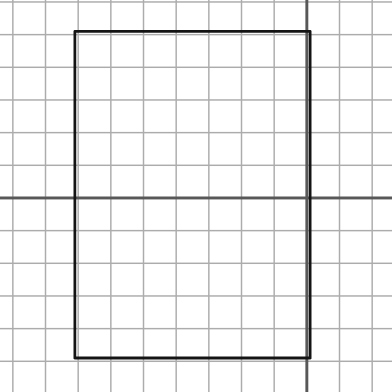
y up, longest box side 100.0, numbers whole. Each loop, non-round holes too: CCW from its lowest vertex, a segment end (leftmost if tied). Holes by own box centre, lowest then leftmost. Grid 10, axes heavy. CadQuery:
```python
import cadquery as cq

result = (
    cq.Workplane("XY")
    .moveTo(-71.0, -49.0)
    .lineTo(1.0, -49.0)
    .lineTo(1.0, 51.0)
    .lineTo(-71.0, 51.0)
    .close()
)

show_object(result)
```